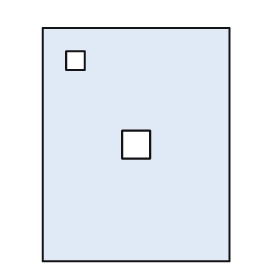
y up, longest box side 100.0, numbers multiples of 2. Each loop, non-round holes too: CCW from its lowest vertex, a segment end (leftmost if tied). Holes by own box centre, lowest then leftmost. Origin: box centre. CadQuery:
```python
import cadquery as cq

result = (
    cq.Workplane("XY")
    .moveTo(-40.0, -50.0)
    .lineTo(40.0, -50.0)
    .lineTo(40.0, 50.0)
    .lineTo(-40.0, 50.0)
    .close()
    .moveTo(-6.0, -6.0)
    .lineTo(6.0, -6.0)
    .lineTo(6.0, 6.0)
    .lineTo(-6.0, 6.0)
    .close()
    .moveTo(-30.0, 32.0)
    .lineTo(-22.0, 32.0)
    .lineTo(-22.0, 40.0)
    .lineTo(-30.0, 40.0)
    .close()
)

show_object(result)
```